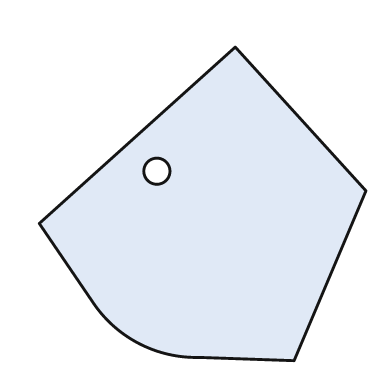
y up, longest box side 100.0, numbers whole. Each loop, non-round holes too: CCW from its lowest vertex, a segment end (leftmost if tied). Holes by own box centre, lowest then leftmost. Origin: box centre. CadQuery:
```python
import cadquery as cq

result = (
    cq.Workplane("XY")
    .moveTo(28.0, -48.0)
    .lineTo(50.0, 4.0)
    .lineTo(10.0, 48.0)
    .lineTo(-50.0, -6.0)
    .lineTo(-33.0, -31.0)
    .threePointArc((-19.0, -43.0), (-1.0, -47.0))
    .close()
    .moveTo(-14.0, 10.0)
    .circle(4.0)
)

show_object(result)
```